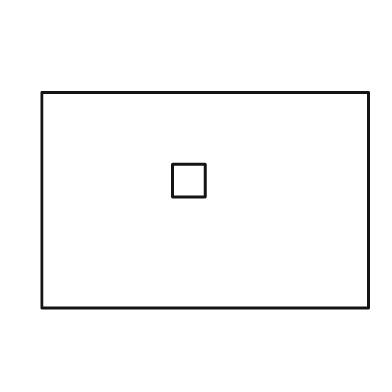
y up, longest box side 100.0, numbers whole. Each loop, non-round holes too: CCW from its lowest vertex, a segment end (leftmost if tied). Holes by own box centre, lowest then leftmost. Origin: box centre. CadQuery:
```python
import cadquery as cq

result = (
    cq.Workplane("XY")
    .moveTo(-50.0, -33.0)
    .lineTo(50.0, -33.0)
    .lineTo(50.0, 33.0)
    .lineTo(-50.0, 33.0)
    .close()
    .moveTo(-10.0, 1.0)
    .lineTo(0.0, 1.0)
    .lineTo(0.0, 11.0)
    .lineTo(-10.0, 11.0)
    .close()
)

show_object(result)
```